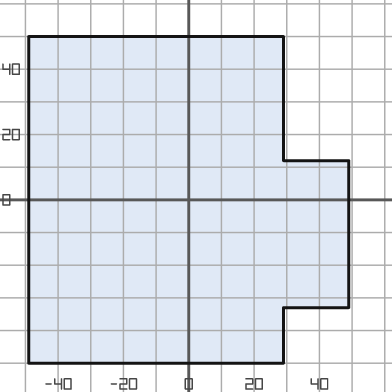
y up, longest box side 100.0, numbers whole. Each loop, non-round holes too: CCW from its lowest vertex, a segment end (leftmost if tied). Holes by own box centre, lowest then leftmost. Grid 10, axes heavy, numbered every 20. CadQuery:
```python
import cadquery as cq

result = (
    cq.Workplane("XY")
    .moveTo(-49.0, -50.0)
    .lineTo(29.0, -50.0)
    .lineTo(29.0, -33.0)
    .lineTo(49.0, -33.0)
    .lineTo(49.0, 12.0)
    .lineTo(29.0, 12.0)
    .lineTo(29.0, 50.0)
    .lineTo(-49.0, 50.0)
    .close()
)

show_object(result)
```